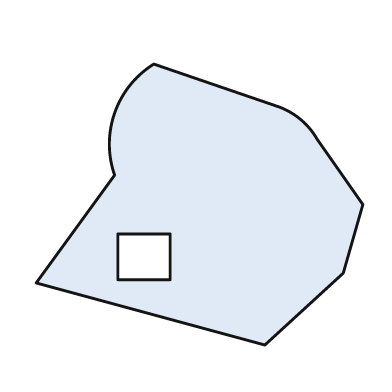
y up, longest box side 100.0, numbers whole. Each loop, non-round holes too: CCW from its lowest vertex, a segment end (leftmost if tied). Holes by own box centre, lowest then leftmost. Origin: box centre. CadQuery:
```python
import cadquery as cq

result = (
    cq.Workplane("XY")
    .moveTo(20.0, -43.0)
    .lineTo(44.0, -21.0)
    .lineTo(50.0, 0.0)
    .lineTo(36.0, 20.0)
    .threePointArc((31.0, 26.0), (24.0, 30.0))
    .lineTo(-14.0, 43.0)
    .threePointArc((-26.0, 28.0), (-26.0, 9.0))
    .lineTo(-50.0, -24.0)
    .close()
    .moveTo(-25.0, -23.0)
    .lineTo(-9.0, -23.0)
    .lineTo(-9.0, -9.0)
    .lineTo(-25.0, -9.0)
    .close()
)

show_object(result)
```